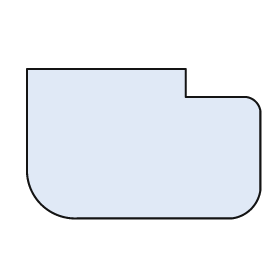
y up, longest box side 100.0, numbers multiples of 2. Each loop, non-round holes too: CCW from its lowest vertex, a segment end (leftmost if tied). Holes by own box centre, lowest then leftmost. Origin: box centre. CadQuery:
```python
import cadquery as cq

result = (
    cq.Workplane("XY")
    .moveTo(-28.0, -32.0)
    .lineTo(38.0, -32.0)
    .threePointArc((46.0, -28.0), (50.0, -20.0))
    .lineTo(50.0, 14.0)
    .threePointArc((48.0, 18.0), (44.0, 20.0))
    .lineTo(18.0, 20.0)
    .lineTo(18.0, 32.0)
    .lineTo(-50.0, 32.0)
    .lineTo(-50.0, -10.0)
    .threePointArc((-44.0, -26.0), (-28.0, -32.0))
    .close()
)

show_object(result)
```